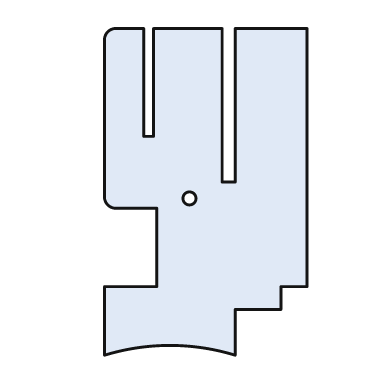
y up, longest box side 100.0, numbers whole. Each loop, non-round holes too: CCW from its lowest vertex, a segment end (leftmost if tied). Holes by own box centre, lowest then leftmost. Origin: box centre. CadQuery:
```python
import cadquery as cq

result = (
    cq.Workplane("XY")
    .moveTo(-31.0, -50.0)
    .threePointArc((-11.0, -47.0), (9.0, -50.0))
    .lineTo(9.0, -36.0)
    .lineTo(23.0, -36.0)
    .lineTo(23.0, -29.0)
    .lineTo(31.0, -29.0)
    .lineTo(31.0, 50.0)
    .lineTo(9.0, 50.0)
    .lineTo(9.0, 3.0)
    .lineTo(5.0, 3.0)
    .lineTo(5.0, 50.0)
    .lineTo(-16.0, 50.0)
    .lineTo(-16.0, 17.0)
    .lineTo(-19.0, 17.0)
    .lineTo(-19.0, 50.0)
    .lineTo(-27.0, 50.0)
    .threePointArc((-30.0, 49.0), (-31.0, 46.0))
    .lineTo(-31.0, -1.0)
    .threePointArc((-30.0, -4.0), (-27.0, -5.0))
    .lineTo(-15.0, -5.0)
    .lineTo(-15.0, -29.0)
    .lineTo(-31.0, -29.0)
    .close()
    .moveTo(-5.0, -2.0)
    .circle(2.0)
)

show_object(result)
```